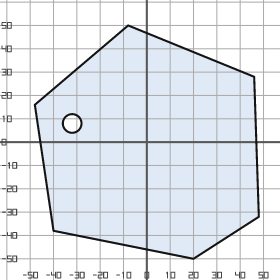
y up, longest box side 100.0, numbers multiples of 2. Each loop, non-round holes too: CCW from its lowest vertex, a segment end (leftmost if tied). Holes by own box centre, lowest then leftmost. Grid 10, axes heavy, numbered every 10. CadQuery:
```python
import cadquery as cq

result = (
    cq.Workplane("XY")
    .moveTo(20.0, -50.0)
    .lineTo(48.0, -32.0)
    .lineTo(46.0, 28.0)
    .lineTo(-8.0, 50.0)
    .lineTo(-48.0, 16.0)
    .lineTo(-40.0, -38.0)
    .close()
    .moveTo(-32.0, 8.0)
    .circle(4.0)
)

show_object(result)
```